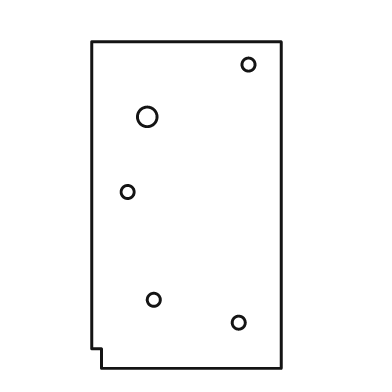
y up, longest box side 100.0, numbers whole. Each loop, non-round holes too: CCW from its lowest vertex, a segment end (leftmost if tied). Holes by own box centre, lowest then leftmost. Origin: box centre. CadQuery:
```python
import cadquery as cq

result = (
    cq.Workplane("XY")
    .moveTo(-26.0, -50.0)
    .lineTo(29.0, -50.0)
    .lineTo(29.0, 50.0)
    .lineTo(-29.0, 50.0)
    .lineTo(-29.0, -44.0)
    .lineTo(-26.0, -44.0)
    .close()
    .moveTo(16.0, -36.0)
    .circle(2.0)
    .moveTo(-10.0, -29.0)
    .circle(2.0)
    .moveTo(-18.0, 4.0)
    .circle(2.0)
    .moveTo(-12.0, 27.0)
    .circle(3.0)
    .moveTo(19.0, 43.0)
    .circle(2.0)
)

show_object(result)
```